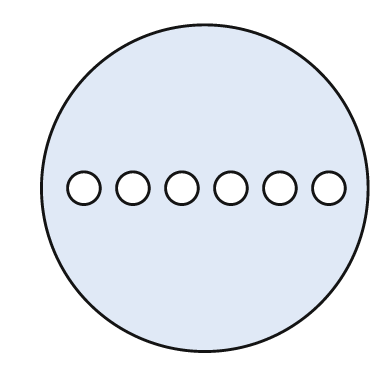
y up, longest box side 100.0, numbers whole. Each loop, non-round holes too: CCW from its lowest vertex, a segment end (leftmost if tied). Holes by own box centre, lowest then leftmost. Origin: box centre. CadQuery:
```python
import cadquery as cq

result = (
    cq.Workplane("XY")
    .moveTo(0.0, 0.0)
    .circle(50.0)
    .moveTo(-37.0, 0.0)
    .circle(5.0)
    .moveTo(-22.0, 0.0)
    .circle(5.0)
    .moveTo(-7.0, 0.0)
    .circle(5.0)
    .moveTo(8.0, 0.0)
    .circle(5.0)
    .moveTo(23.0, 0.0)
    .circle(5.0)
    .moveTo(38.0, 0.0)
    .circle(5.0)
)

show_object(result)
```